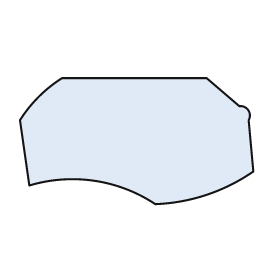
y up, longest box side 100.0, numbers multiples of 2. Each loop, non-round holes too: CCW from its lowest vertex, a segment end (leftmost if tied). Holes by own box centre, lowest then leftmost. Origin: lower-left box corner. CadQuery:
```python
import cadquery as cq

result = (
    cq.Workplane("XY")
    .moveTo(58.0, 0.0)
    .threePointArc((80.0, 4.0), (100.0, 14.0))
    .lineTo(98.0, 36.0)
    .threePointArc((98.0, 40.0), (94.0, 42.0))
    .lineTo(80.0, 54.0)
    .lineTo(18.0, 54.0)
    .threePointArc((8.0, 46.0), (0.0, 36.0))
    .lineTo(4.0, 8.0)
    .threePointArc((32.0, 10.0), (58.0, 0.0))
    .close()
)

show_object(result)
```